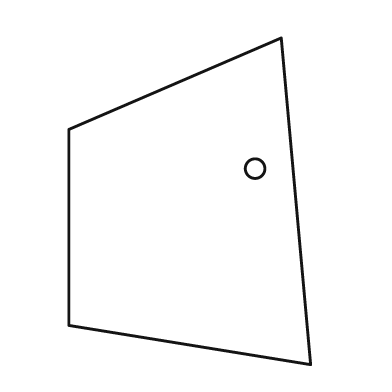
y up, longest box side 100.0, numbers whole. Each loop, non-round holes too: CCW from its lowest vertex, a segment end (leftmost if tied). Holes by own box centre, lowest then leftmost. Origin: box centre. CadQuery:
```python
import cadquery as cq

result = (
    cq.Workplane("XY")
    .moveTo(37.0, -50.0)
    .lineTo(28.0, 50.0)
    .lineTo(-37.0, 22.0)
    .lineTo(-37.0, -38.0)
    .close()
    .moveTo(20.0, 10.0)
    .circle(3.0)
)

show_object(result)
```